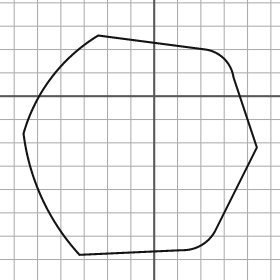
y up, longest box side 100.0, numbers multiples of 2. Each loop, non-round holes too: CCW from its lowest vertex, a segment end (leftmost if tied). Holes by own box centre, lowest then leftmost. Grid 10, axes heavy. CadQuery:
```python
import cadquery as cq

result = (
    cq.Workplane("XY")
    .moveTo(-32.0, -68.0)
    .lineTo(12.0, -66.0)
    .threePointArc((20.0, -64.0), (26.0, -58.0))
    .lineTo(44.0, -22.0)
    .lineTo(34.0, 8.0)
    .threePointArc((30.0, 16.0), (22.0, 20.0))
    .lineTo(-24.0, 26.0)
    .threePointArc((-44.0, 8.0), (-56.0, -16.0))
    .threePointArc((-48.0, -44.0), (-32.0, -68.0))
    .close()
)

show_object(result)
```